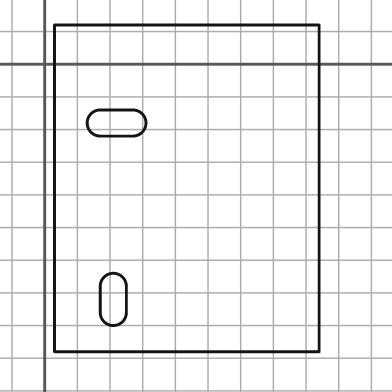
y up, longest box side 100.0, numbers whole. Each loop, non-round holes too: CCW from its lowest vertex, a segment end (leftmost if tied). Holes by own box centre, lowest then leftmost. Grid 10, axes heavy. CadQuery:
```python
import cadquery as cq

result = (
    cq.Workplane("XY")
    .moveTo(3.0, -88.0)
    .lineTo(84.0, -88.0)
    .lineTo(84.0, 12.0)
    .lineTo(3.0, 12.0)
    .close()
    .moveTo(17.0, -76.0)
    .threePointArc((21.0, -80.0), (25.0, -76.0))
    .lineTo(25.0, -68.0)
    .threePointArc((21.0, -64.0), (17.0, -68.0))
    .close()
    .moveTo(17.0, -22.0)
    .lineTo(27.0, -22.0)
    .threePointArc((31.0, -18.0), (27.0, -14.0))
    .lineTo(17.0, -14.0)
    .threePointArc((13.0, -18.0), (17.0, -22.0))
    .close()
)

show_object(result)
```